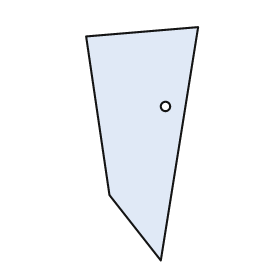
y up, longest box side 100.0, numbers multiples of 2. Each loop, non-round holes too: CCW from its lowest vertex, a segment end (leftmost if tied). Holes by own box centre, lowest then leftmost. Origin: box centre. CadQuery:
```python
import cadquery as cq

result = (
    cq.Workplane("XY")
    .moveTo(8.0, -50.0)
    .lineTo(24.0, 50.0)
    .lineTo(-24.0, 46.0)
    .lineTo(-14.0, -22.0)
    .close()
    .moveTo(10.0, 16.0)
    .circle(2.0)
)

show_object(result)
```